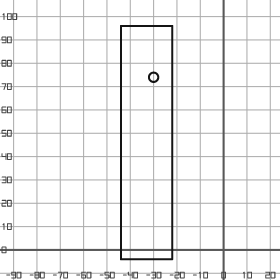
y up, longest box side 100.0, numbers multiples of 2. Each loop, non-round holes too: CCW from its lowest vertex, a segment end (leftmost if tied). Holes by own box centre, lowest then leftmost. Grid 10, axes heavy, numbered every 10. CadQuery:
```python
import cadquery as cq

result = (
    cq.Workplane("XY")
    .moveTo(-44.0, -4.0)
    .lineTo(-22.0, -4.0)
    .lineTo(-22.0, 96.0)
    .lineTo(-44.0, 96.0)
    .close()
    .moveTo(-30.0, 74.0)
    .circle(2.0)
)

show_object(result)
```